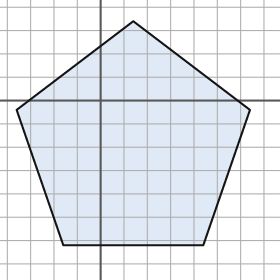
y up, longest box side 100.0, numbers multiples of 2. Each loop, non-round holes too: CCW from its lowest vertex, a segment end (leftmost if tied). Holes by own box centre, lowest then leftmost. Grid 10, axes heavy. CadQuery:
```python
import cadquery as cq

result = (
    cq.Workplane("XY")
    .moveTo(-16.0, -62.0)
    .lineTo(44.0, -62.0)
    .lineTo(64.0, -4.0)
    .lineTo(14.0, 34.0)
    .lineTo(-36.0, -4.0)
    .close()
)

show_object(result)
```